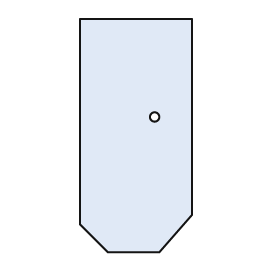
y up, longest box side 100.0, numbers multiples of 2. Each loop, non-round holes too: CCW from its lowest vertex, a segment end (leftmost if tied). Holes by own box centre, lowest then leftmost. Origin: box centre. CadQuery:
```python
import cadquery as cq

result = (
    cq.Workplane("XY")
    .moveTo(-12.0, -50.0)
    .lineTo(10.0, -50.0)
    .lineTo(24.0, -34.0)
    .lineTo(24.0, 50.0)
    .lineTo(-24.0, 50.0)
    .lineTo(-24.0, -38.0)
    .close()
    .moveTo(8.0, 8.0)
    .circle(2.0)
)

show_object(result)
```